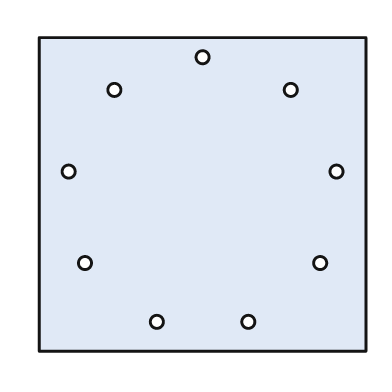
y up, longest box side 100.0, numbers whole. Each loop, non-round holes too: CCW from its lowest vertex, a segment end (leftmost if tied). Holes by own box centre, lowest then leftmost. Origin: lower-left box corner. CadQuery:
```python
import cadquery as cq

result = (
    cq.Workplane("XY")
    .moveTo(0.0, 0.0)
    .lineTo(100.0, 0.0)
    .lineTo(100.0, 96.0)
    .lineTo(0.0, 96.0)
    .close()
    .moveTo(36.0, 9.0)
    .circle(2.0)
    .moveTo(64.0, 9.0)
    .circle(2.0)
    .moveTo(14.0, 27.0)
    .circle(2.0)
    .moveTo(86.0, 27.0)
    .circle(2.0)
    .moveTo(9.0, 55.0)
    .circle(2.0)
    .moveTo(91.0, 55.0)
    .circle(2.0)
    .moveTo(23.0, 80.0)
    .circle(2.0)
    .moveTo(77.0, 80.0)
    .circle(2.0)
    .moveTo(50.0, 90.0)
    .circle(2.0)
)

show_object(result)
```